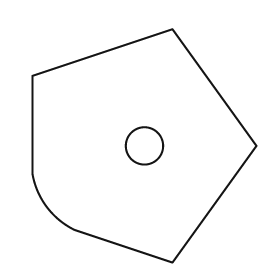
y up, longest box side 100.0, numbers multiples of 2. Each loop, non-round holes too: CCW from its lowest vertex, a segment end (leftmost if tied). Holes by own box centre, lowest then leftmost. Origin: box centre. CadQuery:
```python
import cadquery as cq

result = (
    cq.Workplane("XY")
    .moveTo(12.0, -50.0)
    .lineTo(48.0, 0.0)
    .lineTo(12.0, 50.0)
    .lineTo(-48.0, 30.0)
    .lineTo(-48.0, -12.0)
    .threePointArc((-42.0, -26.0), (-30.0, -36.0))
    .close()
    .moveTo(0.0, 0.0)
    .circle(8.0)
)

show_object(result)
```